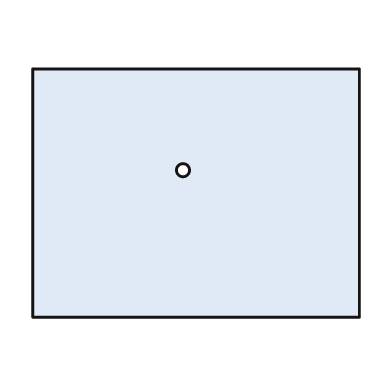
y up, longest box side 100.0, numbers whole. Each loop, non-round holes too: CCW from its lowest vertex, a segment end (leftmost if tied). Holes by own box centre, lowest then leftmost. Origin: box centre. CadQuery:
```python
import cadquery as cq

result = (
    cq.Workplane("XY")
    .moveTo(-50.0, -38.0)
    .lineTo(50.0, -38.0)
    .lineTo(50.0, 38.0)
    .lineTo(-50.0, 38.0)
    .close()
    .moveTo(-4.0, 7.0)
    .circle(2.0)
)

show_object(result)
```